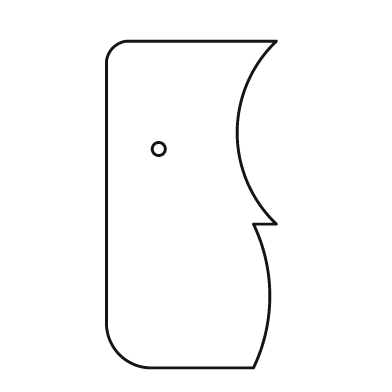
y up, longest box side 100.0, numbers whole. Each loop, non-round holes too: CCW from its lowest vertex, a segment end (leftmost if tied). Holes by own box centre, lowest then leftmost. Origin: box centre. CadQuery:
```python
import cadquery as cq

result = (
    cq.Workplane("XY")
    .moveTo(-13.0, -50.0)
    .lineTo(19.0, -50.0)
    .threePointArc((24.0, -28.0), (19.0, -6.0))
    .lineTo(26.0, -6.0)
    .threePointArc((14.0, 22.0), (26.0, 50.0))
    .lineTo(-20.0, 50.0)
    .threePointArc((-24.0, 48.0), (-26.0, 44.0))
    .lineTo(-26.0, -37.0)
    .threePointArc((-22.0, -46.0), (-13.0, -50.0))
    .close()
    .moveTo(-10.0, 17.0)
    .circle(2.0)
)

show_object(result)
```